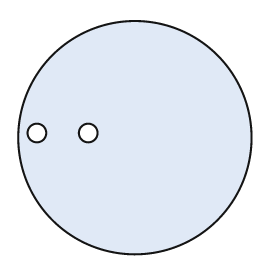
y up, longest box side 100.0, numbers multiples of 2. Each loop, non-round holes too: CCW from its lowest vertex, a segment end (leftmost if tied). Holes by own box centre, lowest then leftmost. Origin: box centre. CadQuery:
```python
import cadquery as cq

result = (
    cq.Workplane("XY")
    .moveTo(0.0, 0.0)
    .circle(50.0)
    .moveTo(-42.0, 2.0)
    .circle(4.0)
    .moveTo(-20.0, 2.0)
    .circle(4.0)
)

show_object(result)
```